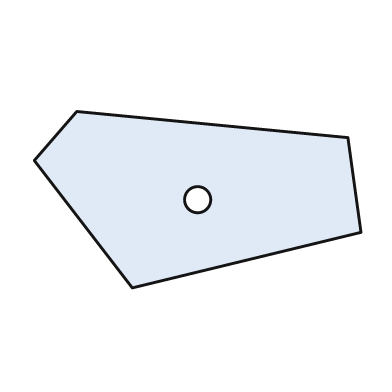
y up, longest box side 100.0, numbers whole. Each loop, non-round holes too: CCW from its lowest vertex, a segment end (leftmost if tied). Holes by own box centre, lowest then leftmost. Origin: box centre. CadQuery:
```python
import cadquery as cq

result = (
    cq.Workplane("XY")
    .moveTo(-20.0, -27.0)
    .lineTo(50.0, -10.0)
    .lineTo(46.0, 19.0)
    .lineTo(-37.0, 27.0)
    .lineTo(-50.0, 12.0)
    .close()
    .moveTo(0.0, 0.0)
    .circle(4.0)
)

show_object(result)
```